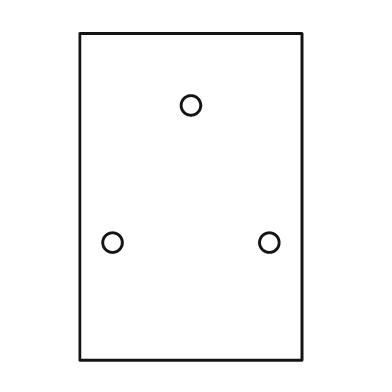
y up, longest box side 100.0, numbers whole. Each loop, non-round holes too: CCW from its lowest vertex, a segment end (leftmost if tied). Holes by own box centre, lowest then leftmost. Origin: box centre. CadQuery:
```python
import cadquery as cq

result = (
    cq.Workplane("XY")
    .moveTo(-34.0, -50.0)
    .lineTo(34.0, -50.0)
    .lineTo(34.0, 50.0)
    .lineTo(-34.0, 50.0)
    .close()
    .moveTo(-24.0, -14.0)
    .circle(3.0)
    .moveTo(24.0, -14.0)
    .circle(3.0)
    .moveTo(0.0, 28.0)
    .circle(3.0)
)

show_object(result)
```